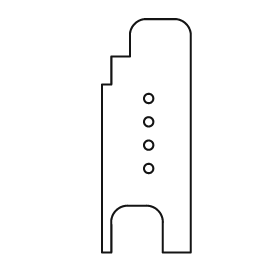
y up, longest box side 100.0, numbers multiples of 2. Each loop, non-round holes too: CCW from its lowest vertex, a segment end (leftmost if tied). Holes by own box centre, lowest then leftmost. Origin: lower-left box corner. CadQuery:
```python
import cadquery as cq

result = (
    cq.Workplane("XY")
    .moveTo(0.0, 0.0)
    .lineTo(4.0, 0.0)
    .lineTo(4.0, 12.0)
    .threePointArc((6.0, 18.0), (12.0, 20.0))
    .lineTo(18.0, 20.0)
    .threePointArc((24.0, 18.0), (26.0, 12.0))
    .lineTo(26.0, 0.0)
    .lineTo(38.0, 0.0)
    .lineTo(38.0, 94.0)
    .threePointArc((36.0, 98.0), (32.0, 100.0))
    .lineTo(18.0, 100.0)
    .threePointArc((14.0, 98.0), (12.0, 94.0))
    .lineTo(12.0, 84.0)
    .lineTo(4.0, 84.0)
    .lineTo(4.0, 72.0)
    .lineTo(0.0, 72.0)
    .close()
    .moveTo(20.0, 36.0)
    .circle(2.0)
    .moveTo(20.0, 46.0)
    .circle(2.0)
    .moveTo(20.0, 56.0)
    .circle(2.0)
    .moveTo(20.0, 66.0)
    .circle(2.0)
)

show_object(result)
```